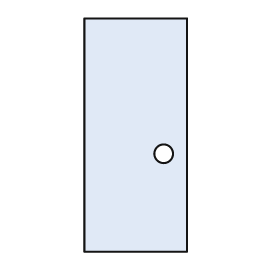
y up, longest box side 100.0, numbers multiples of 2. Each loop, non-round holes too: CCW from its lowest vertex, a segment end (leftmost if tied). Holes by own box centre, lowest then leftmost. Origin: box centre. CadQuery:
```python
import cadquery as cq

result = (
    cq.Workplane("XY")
    .moveTo(-22.0, -50.0)
    .lineTo(22.0, -50.0)
    .lineTo(22.0, 50.0)
    .lineTo(-22.0, 50.0)
    .close()
    .moveTo(12.0, -8.0)
    .circle(4.0)
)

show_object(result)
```